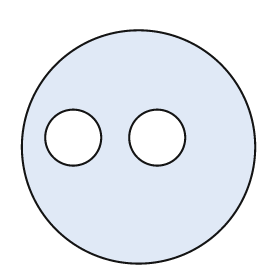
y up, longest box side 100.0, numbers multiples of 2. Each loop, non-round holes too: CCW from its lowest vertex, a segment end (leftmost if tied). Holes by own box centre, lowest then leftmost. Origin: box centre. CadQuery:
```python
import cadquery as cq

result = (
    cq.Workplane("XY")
    .moveTo(0.0, 0.0)
    .circle(50.0)
    .moveTo(-28.0, 4.0)
    .circle(12.0)
    .moveTo(8.0, 4.0)
    .circle(12.0)
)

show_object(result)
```